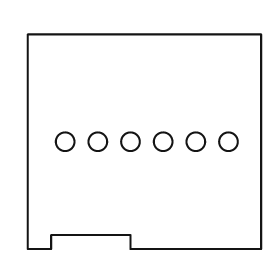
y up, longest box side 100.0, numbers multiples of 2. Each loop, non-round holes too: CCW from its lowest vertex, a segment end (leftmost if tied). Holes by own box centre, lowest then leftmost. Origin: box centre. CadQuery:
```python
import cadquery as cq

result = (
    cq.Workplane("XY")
    .moveTo(-50.0, -46.0)
    .lineTo(-40.0, -46.0)
    .lineTo(-40.0, -40.0)
    .lineTo(-6.0, -40.0)
    .lineTo(-6.0, -46.0)
    .lineTo(50.0, -46.0)
    .lineTo(50.0, 46.0)
    .lineTo(-50.0, 46.0)
    .close()
    .moveTo(-34.0, 0.0)
    .circle(4.0)
    .moveTo(-20.0, 0.0)
    .circle(4.0)
    .moveTo(-6.0, 0.0)
    .circle(4.0)
    .moveTo(8.0, 0.0)
    .circle(4.0)
    .moveTo(22.0, 0.0)
    .circle(4.0)
    .moveTo(36.0, 0.0)
    .circle(4.0)
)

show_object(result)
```